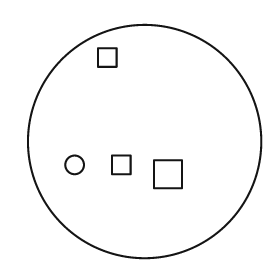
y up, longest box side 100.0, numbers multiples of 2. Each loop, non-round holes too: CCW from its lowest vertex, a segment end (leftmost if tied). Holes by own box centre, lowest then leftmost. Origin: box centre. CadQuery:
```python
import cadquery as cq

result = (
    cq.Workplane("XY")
    .moveTo(0.0, 0.0)
    .circle(50.0)
    .moveTo(4.0, -20.0)
    .lineTo(16.0, -20.0)
    .lineTo(16.0, -8.0)
    .lineTo(4.0, -8.0)
    .close()
    .moveTo(-30.0, -10.0)
    .circle(4.0)
    .moveTo(-14.0, -14.0)
    .lineTo(-6.0, -14.0)
    .lineTo(-6.0, -6.0)
    .lineTo(-14.0, -6.0)
    .close()
    .moveTo(-20.0, 32.0)
    .lineTo(-12.0, 32.0)
    .lineTo(-12.0, 40.0)
    .lineTo(-20.0, 40.0)
    .close()
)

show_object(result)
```